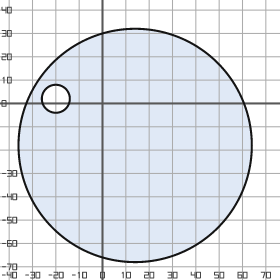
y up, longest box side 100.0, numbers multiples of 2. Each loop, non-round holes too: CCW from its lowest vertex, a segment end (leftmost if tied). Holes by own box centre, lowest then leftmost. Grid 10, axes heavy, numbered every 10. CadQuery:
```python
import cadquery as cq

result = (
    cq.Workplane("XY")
    .moveTo(14.0, -18.0)
    .circle(50.0)
    .moveTo(-20.0, 2.0)
    .circle(6.0)
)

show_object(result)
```